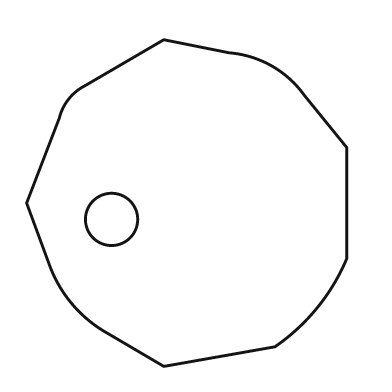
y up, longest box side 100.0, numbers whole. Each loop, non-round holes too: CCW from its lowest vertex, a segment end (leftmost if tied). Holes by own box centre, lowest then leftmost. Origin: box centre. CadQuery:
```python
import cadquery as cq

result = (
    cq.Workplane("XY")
    .moveTo(-7.0, -50.0)
    .lineTo(27.0, -44.0)
    .threePointArc((40.0, -32.0), (49.0, -17.0))
    .lineTo(49.0, 17.0)
    .lineTo(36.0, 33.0)
    .threePointArc((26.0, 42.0), (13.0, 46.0))
    .lineTo(-7.0, 50.0)
    .lineTo(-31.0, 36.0)
    .threePointArc((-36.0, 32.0), (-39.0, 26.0))
    .lineTo(-49.0, 0.0)
    .lineTo(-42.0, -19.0)
    .threePointArc((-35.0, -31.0), (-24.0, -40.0))
    .close()
    .moveTo(-23.0, -5.0)
    .circle(8.0)
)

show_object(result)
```